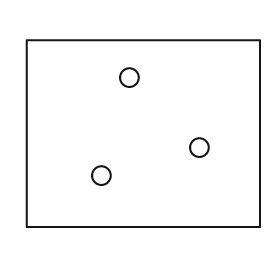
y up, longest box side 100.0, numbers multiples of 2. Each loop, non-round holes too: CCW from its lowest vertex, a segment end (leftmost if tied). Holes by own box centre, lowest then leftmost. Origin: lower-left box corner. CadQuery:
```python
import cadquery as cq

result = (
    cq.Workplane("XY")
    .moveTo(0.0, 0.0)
    .lineTo(100.0, 0.0)
    .lineTo(100.0, 80.0)
    .lineTo(0.0, 80.0)
    .close()
    .moveTo(32.0, 22.0)
    .circle(4.0)
    .moveTo(74.0, 34.0)
    .circle(4.0)
    .moveTo(44.0, 64.0)
    .circle(4.0)
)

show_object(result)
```